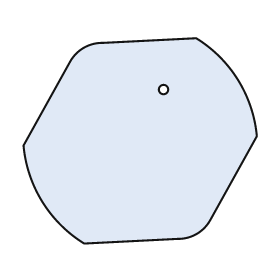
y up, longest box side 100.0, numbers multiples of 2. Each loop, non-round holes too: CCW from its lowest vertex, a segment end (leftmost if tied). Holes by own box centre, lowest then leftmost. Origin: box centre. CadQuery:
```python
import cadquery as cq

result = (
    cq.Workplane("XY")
    .moveTo(-24.0, -44.0)
    .lineTo(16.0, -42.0)
    .threePointArc((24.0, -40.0), (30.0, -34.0))
    .lineTo(50.0, 2.0)
    .threePointArc((42.0, 26.0), (24.0, 44.0))
    .lineTo(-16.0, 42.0)
    .threePointArc((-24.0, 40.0), (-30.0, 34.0))
    .lineTo(-50.0, -2.0)
    .threePointArc((-42.0, -26.0), (-24.0, -44.0))
    .close()
    .moveTo(10.0, 22.0)
    .circle(2.0)
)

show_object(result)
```